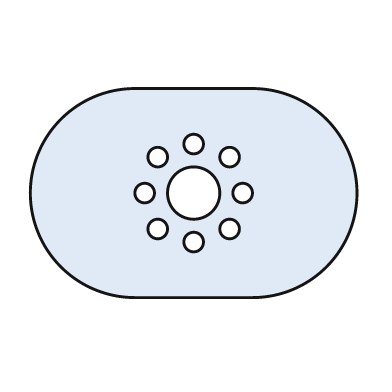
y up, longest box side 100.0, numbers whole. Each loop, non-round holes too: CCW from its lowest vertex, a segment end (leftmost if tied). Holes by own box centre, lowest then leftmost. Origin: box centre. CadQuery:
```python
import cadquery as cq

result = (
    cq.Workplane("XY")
    .moveTo(-18.0, -32.0)
    .lineTo(18.0, -32.0)
    .threePointArc((50.0, 0.0), (18.0, 32.0))
    .lineTo(-18.0, 32.0)
    .threePointArc((-50.0, 0.0), (-18.0, -32.0))
    .close()
    .moveTo(0.0, -15.0)
    .circle(3.0)
    .moveTo(-11.0, -11.0)
    .circle(3.0)
    .moveTo(11.0, -11.0)
    .circle(3.0)
    .moveTo(-15.0, 0.0)
    .circle(3.0)
    .moveTo(0.0, 0.0)
    .circle(8.0)
    .moveTo(15.0, 0.0)
    .circle(3.0)
    .moveTo(-11.0, 11.0)
    .circle(3.0)
    .moveTo(11.0, 11.0)
    .circle(3.0)
    .moveTo(0.0, 15.0)
    .circle(3.0)
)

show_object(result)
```